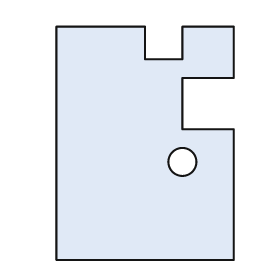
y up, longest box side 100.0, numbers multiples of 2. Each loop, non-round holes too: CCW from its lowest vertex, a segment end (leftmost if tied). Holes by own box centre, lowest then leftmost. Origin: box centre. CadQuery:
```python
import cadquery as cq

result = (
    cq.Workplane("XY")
    .moveTo(-38.0, -50.0)
    .lineTo(38.0, -50.0)
    .lineTo(38.0, 6.0)
    .lineTo(16.0, 6.0)
    .lineTo(16.0, 28.0)
    .lineTo(38.0, 28.0)
    .lineTo(38.0, 50.0)
    .lineTo(16.0, 50.0)
    .lineTo(16.0, 36.0)
    .lineTo(0.0, 36.0)
    .lineTo(0.0, 50.0)
    .lineTo(-38.0, 50.0)
    .close()
    .moveTo(16.0, -8.0)
    .circle(6.0)
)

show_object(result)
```